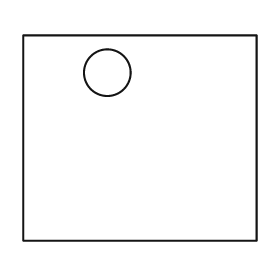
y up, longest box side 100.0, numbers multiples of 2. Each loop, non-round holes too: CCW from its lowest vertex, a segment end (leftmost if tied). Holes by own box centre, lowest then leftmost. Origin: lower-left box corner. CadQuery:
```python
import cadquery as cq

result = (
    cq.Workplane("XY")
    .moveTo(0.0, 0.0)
    .lineTo(100.0, 0.0)
    .lineTo(100.0, 88.0)
    .lineTo(0.0, 88.0)
    .close()
    .moveTo(36.0, 72.0)
    .circle(10.0)
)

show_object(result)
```